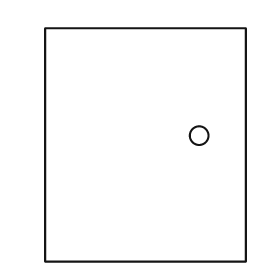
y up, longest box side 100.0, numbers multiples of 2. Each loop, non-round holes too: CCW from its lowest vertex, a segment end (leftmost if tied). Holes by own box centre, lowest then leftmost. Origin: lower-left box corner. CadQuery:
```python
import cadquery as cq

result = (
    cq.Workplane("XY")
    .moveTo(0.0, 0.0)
    .lineTo(86.0, 0.0)
    .lineTo(86.0, 100.0)
    .lineTo(0.0, 100.0)
    .close()
    .moveTo(66.0, 54.0)
    .circle(4.0)
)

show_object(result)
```